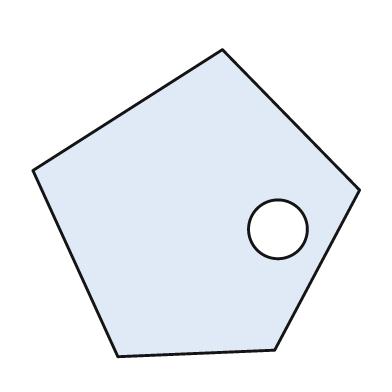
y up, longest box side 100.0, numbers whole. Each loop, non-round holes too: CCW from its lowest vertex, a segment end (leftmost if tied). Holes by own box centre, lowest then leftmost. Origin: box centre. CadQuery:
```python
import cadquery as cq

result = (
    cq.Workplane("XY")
    .moveTo(-24.0, -47.0)
    .lineTo(24.0, -45.0)
    .lineTo(50.0, 4.0)
    .lineTo(8.0, 47.0)
    .lineTo(-50.0, 10.0)
    .close()
    .moveTo(25.0, -8.0)
    .circle(9.0)
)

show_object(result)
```